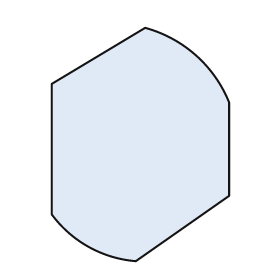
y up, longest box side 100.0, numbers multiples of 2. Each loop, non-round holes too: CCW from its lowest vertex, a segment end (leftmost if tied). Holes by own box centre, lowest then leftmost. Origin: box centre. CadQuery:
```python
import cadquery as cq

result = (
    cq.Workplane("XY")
    .moveTo(-2.0, -50.0)
    .lineTo(38.0, -22.0)
    .lineTo(38.0, 18.0)
    .threePointArc((24.0, 38.0), (2.0, 50.0))
    .lineTo(-38.0, 26.0)
    .lineTo(-38.0, -30.0)
    .threePointArc((-22.0, -44.0), (-2.0, -50.0))
    .close()
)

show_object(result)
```